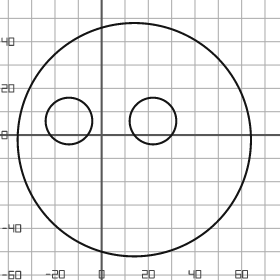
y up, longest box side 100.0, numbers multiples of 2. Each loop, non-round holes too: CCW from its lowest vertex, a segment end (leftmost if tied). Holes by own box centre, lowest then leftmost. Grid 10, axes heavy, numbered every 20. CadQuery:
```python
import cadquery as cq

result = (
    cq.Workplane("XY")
    .moveTo(14.0, -2.0)
    .circle(50.0)
    .moveTo(-14.0, 6.0)
    .circle(10.0)
    .moveTo(22.0, 6.0)
    .circle(10.0)
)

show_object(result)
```